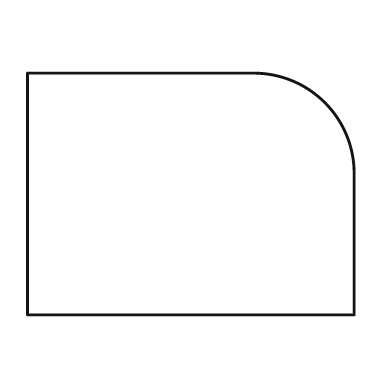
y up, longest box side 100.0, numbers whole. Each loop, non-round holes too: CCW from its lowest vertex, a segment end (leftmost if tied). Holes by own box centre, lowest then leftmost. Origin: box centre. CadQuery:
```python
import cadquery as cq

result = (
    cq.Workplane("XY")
    .moveTo(-50.0, -37.0)
    .lineTo(50.0, -37.0)
    .lineTo(50.0, 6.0)
    .threePointArc((41.0, 28.0), (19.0, 37.0))
    .lineTo(-50.0, 37.0)
    .close()
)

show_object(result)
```